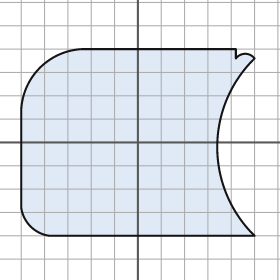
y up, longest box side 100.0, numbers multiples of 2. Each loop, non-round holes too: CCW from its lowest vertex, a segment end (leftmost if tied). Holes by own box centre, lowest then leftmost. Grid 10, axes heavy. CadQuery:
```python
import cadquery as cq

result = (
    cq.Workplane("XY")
    .moveTo(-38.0, -40.0)
    .lineTo(50.0, -40.0)
    .threePointArc((34.0, -2.0), (50.0, 36.0))
    .threePointArc((46.0, 38.0), (42.0, 36.0))
    .lineTo(42.0, 40.0)
    .lineTo(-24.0, 40.0)
    .threePointArc((-42.0, 32.0), (-50.0, 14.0))
    .lineTo(-50.0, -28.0)
    .threePointArc((-46.0, -36.0), (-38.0, -40.0))
    .close()
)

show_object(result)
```